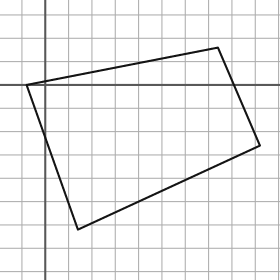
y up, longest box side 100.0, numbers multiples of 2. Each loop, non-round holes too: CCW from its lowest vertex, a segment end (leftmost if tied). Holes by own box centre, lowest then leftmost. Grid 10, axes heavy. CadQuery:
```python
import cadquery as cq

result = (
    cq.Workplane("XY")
    .moveTo(14.0, -62.0)
    .lineTo(92.0, -26.0)
    .lineTo(74.0, 16.0)
    .lineTo(-8.0, 0.0)
    .close()
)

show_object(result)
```